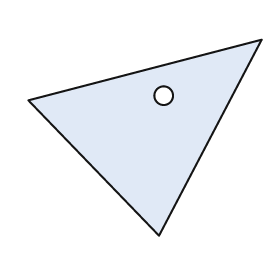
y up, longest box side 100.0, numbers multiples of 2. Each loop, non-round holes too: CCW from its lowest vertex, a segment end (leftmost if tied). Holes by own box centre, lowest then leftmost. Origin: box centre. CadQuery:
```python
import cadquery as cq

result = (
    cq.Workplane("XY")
    .moveTo(6.0, -42.0)
    .lineTo(50.0, 42.0)
    .lineTo(-50.0, 16.0)
    .close()
    .moveTo(8.0, 18.0)
    .circle(4.0)
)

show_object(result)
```